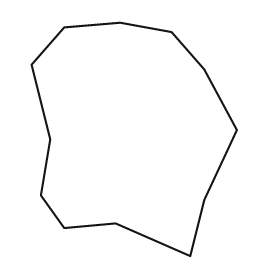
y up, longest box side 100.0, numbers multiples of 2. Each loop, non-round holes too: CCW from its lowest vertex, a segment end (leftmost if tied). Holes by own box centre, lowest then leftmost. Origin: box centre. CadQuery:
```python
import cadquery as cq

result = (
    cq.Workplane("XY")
    .moveTo(24.0, -50.0)
    .lineTo(30.0, -26.0)
    .lineTo(44.0, 4.0)
    .lineTo(30.0, 30.0)
    .lineTo(16.0, 46.0)
    .lineTo(-6.0, 50.0)
    .lineTo(-30.0, 48.0)
    .lineTo(-44.0, 32.0)
    .lineTo(-36.0, 0.0)
    .lineTo(-40.0, -24.0)
    .lineTo(-30.0, -38.0)
    .lineTo(-8.0, -36.0)
    .close()
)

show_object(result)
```